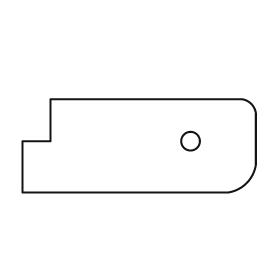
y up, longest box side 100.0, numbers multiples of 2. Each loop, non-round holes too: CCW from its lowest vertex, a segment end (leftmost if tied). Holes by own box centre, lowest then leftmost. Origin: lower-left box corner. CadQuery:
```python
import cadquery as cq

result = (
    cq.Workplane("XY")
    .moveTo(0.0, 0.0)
    .lineTo(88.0, 0.0)
    .threePointArc((96.0, 4.0), (100.0, 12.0))
    .lineTo(100.0, 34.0)
    .threePointArc((98.0, 38.0), (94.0, 40.0))
    .lineTo(12.0, 40.0)
    .lineTo(12.0, 22.0)
    .lineTo(0.0, 22.0)
    .close()
    .moveTo(72.0, 22.0)
    .circle(4.0)
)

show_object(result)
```